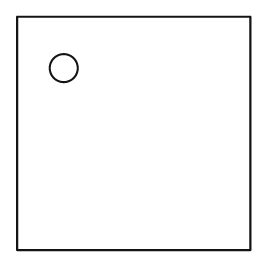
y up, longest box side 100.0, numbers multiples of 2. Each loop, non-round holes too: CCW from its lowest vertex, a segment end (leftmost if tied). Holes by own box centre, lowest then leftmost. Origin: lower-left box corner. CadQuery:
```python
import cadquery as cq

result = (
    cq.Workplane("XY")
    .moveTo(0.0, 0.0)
    .lineTo(100.0, 0.0)
    .lineTo(100.0, 100.0)
    .lineTo(0.0, 100.0)
    .close()
    .moveTo(20.0, 78.0)
    .circle(6.0)
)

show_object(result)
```